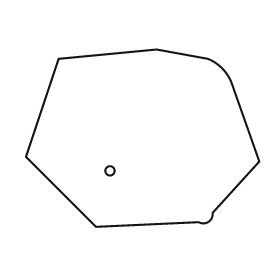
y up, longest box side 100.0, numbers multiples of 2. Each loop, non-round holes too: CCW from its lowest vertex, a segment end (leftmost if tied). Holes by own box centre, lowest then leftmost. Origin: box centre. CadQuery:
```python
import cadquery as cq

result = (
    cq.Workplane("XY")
    .moveTo(-20.0, -38.0)
    .lineTo(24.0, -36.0)
    .threePointArc((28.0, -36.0), (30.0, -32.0))
    .lineTo(50.0, -10.0)
    .lineTo(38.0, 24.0)
    .threePointArc((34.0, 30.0), (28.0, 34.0))
    .lineTo(6.0, 38.0)
    .lineTo(-36.0, 34.0)
    .lineTo(-50.0, -8.0)
    .close()
    .moveTo(-14.0, -14.0)
    .circle(2.0)
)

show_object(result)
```